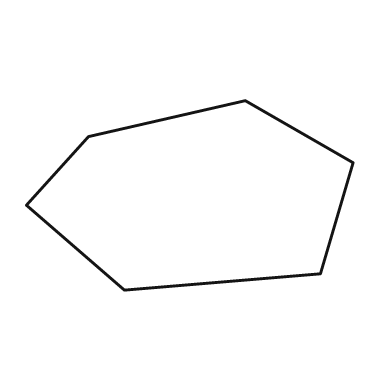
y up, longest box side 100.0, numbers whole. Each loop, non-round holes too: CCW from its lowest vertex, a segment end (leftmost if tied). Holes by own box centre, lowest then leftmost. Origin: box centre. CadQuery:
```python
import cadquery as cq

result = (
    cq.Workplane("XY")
    .moveTo(-20.0, -29.0)
    .lineTo(40.0, -24.0)
    .lineTo(50.0, 10.0)
    .lineTo(17.0, 29.0)
    .lineTo(-31.0, 18.0)
    .lineTo(-50.0, -3.0)
    .close()
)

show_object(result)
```